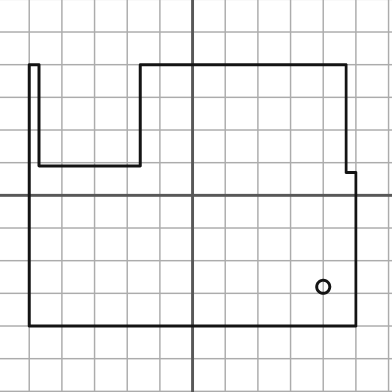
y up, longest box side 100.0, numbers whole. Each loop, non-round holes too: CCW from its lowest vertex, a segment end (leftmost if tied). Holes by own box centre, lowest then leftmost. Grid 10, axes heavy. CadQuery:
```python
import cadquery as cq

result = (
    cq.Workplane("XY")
    .moveTo(-50.0, -40.0)
    .lineTo(50.0, -40.0)
    .lineTo(50.0, 7.0)
    .lineTo(47.0, 7.0)
    .lineTo(47.0, 40.0)
    .lineTo(-16.0, 40.0)
    .lineTo(-16.0, 9.0)
    .lineTo(-47.0, 9.0)
    .lineTo(-47.0, 40.0)
    .lineTo(-50.0, 40.0)
    .close()
    .moveTo(40.0, -28.0)
    .circle(2.0)
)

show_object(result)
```